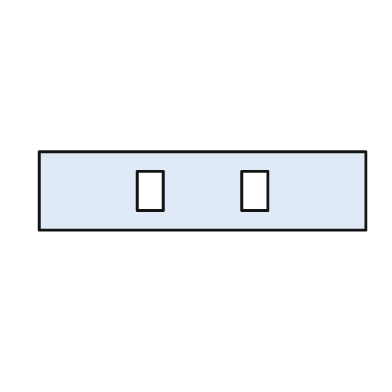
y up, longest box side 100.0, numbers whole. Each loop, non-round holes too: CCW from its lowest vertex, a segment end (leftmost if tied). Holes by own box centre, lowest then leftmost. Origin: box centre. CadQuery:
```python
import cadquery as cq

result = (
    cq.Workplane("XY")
    .moveTo(-50.0, -12.0)
    .lineTo(50.0, -12.0)
    .lineTo(50.0, 12.0)
    .lineTo(-50.0, 12.0)
    .close()
    .moveTo(-20.0, -6.0)
    .lineTo(-12.0, -6.0)
    .lineTo(-12.0, 6.0)
    .lineTo(-20.0, 6.0)
    .close()
    .moveTo(12.0, -6.0)
    .lineTo(20.0, -6.0)
    .lineTo(20.0, 6.0)
    .lineTo(12.0, 6.0)
    .close()
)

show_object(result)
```